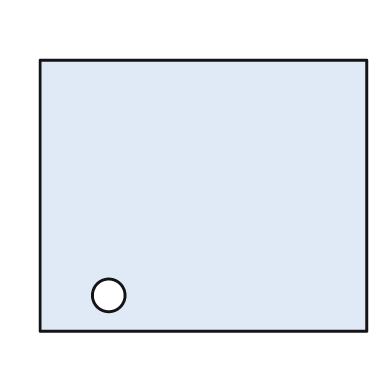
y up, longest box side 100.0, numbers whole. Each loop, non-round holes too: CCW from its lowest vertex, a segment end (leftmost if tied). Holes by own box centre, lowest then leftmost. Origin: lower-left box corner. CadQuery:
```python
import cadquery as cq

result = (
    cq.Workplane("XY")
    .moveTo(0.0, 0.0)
    .lineTo(100.0, 0.0)
    .lineTo(100.0, 83.0)
    .lineTo(0.0, 83.0)
    .close()
    .moveTo(21.0, 11.0)
    .circle(5.0)
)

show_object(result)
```